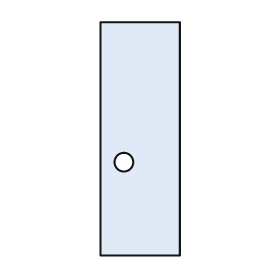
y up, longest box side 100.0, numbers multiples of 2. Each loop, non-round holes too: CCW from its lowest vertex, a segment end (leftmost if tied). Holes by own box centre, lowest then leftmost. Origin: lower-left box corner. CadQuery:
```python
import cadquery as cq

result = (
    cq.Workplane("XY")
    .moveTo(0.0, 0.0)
    .lineTo(34.0, 0.0)
    .lineTo(34.0, 100.0)
    .lineTo(0.0, 100.0)
    .close()
    .moveTo(10.0, 40.0)
    .circle(4.0)
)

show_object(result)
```